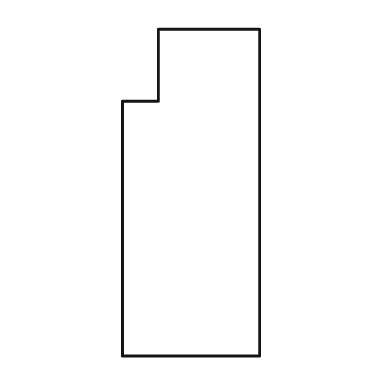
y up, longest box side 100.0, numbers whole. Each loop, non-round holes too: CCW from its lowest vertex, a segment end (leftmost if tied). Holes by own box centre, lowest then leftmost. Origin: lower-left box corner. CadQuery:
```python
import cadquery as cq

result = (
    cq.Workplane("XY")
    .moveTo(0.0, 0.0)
    .lineTo(42.0, 0.0)
    .lineTo(42.0, 100.0)
    .lineTo(11.0, 100.0)
    .lineTo(11.0, 78.0)
    .lineTo(0.0, 78.0)
    .close()
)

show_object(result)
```